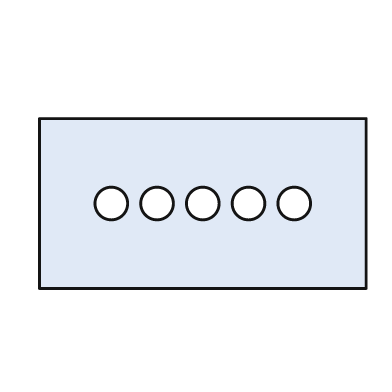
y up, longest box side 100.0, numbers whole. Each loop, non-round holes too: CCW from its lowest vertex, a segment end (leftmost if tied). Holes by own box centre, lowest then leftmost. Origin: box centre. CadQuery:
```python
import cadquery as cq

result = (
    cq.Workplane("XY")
    .moveTo(-50.0, -26.0)
    .lineTo(50.0, -26.0)
    .lineTo(50.0, 26.0)
    .lineTo(-50.0, 26.0)
    .close()
    .moveTo(-28.0, 0.0)
    .circle(5.0)
    .moveTo(-14.0, 0.0)
    .circle(5.0)
    .moveTo(0.0, 0.0)
    .circle(5.0)
    .moveTo(14.0, 0.0)
    .circle(5.0)
    .moveTo(28.0, 0.0)
    .circle(5.0)
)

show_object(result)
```